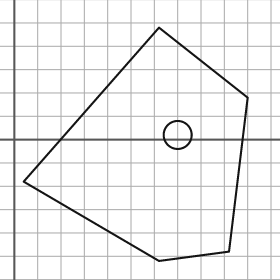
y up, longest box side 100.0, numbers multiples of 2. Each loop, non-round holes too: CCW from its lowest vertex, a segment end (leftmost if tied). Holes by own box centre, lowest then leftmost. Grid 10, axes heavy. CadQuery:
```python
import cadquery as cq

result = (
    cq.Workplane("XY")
    .moveTo(62.0, -52.0)
    .lineTo(92.0, -48.0)
    .lineTo(100.0, 18.0)
    .lineTo(62.0, 48.0)
    .lineTo(4.0, -18.0)
    .close()
    .moveTo(70.0, 2.0)
    .circle(6.0)
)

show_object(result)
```